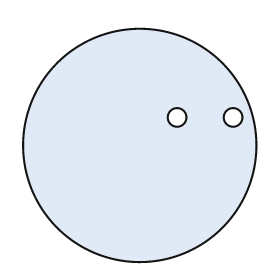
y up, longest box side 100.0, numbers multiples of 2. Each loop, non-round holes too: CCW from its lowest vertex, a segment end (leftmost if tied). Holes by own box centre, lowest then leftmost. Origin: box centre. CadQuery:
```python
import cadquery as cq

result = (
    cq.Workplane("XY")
    .moveTo(0.0, 0.0)
    .circle(50.0)
    .moveTo(16.0, 12.0)
    .circle(4.0)
    .moveTo(40.0, 12.0)
    .circle(4.0)
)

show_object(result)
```